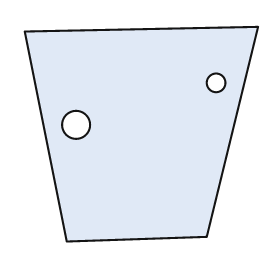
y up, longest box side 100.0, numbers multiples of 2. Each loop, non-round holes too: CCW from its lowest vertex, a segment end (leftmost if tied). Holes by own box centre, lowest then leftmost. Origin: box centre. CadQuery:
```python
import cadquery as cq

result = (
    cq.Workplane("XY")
    .moveTo(-32.0, -46.0)
    .lineTo(28.0, -44.0)
    .lineTo(50.0, 46.0)
    .lineTo(-50.0, 44.0)
    .close()
    .moveTo(-28.0, 4.0)
    .circle(6.0)
    .moveTo(32.0, 22.0)
    .circle(4.0)
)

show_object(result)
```